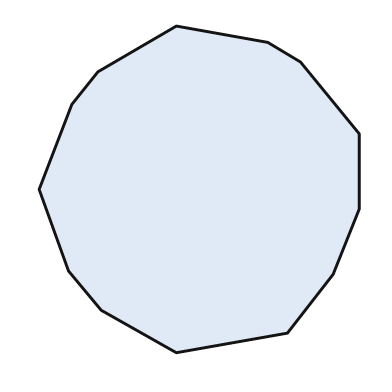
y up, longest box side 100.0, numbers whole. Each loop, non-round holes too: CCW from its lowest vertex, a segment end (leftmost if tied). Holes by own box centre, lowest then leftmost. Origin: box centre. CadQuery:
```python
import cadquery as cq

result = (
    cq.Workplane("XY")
    .moveTo(-7.0, -50.0)
    .lineTo(27.0, -44.0)
    .lineTo(41.0, -26.0)
    .lineTo(49.0, -6.0)
    .lineTo(49.0, 17.0)
    .lineTo(31.0, 39.0)
    .lineTo(21.0, 45.0)
    .lineTo(-7.0, 50.0)
    .lineTo(-31.0, 36.0)
    .lineTo(-39.0, 26.0)
    .lineTo(-49.0, 0.0)
    .lineTo(-40.0, -25.0)
    .lineTo(-30.0, -37.0)
    .close()
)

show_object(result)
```